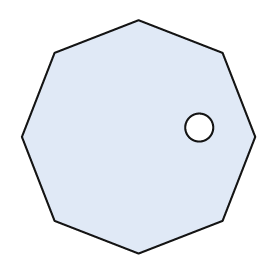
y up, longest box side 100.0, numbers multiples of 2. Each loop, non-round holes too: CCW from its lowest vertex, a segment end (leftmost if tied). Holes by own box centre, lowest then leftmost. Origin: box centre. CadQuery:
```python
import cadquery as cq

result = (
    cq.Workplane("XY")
    .moveTo(0.0, -50.0)
    .lineTo(36.0, -36.0)
    .lineTo(50.0, 0.0)
    .lineTo(36.0, 36.0)
    .lineTo(0.0, 50.0)
    .lineTo(-36.0, 36.0)
    .lineTo(-50.0, 0.0)
    .lineTo(-36.0, -36.0)
    .close()
    .moveTo(26.0, 4.0)
    .circle(6.0)
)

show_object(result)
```